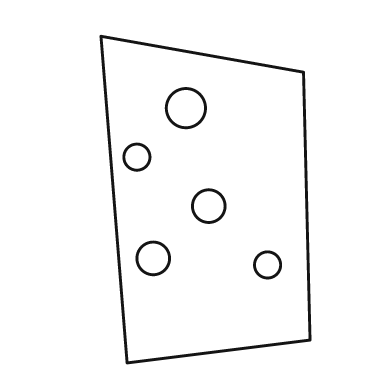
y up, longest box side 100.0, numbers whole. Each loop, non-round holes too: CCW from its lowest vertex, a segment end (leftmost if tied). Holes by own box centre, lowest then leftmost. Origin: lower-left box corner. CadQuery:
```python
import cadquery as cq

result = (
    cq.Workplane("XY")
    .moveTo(8.0, 0.0)
    .lineTo(64.0, 7.0)
    .lineTo(62.0, 89.0)
    .lineTo(0.0, 100.0)
    .close()
    .moveTo(51.0, 30.0)
    .circle(4.0)
    .moveTo(16.0, 32.0)
    .circle(5.0)
    .moveTo(33.0, 48.0)
    .circle(5.0)
    .moveTo(11.0, 63.0)
    .circle(4.0)
    .moveTo(26.0, 78.0)
    .circle(6.0)
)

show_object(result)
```